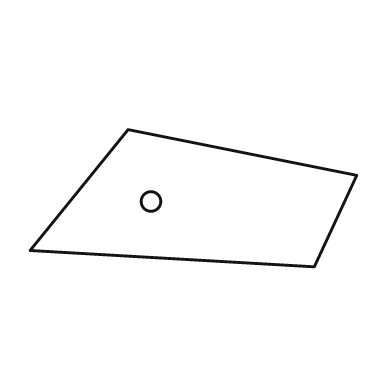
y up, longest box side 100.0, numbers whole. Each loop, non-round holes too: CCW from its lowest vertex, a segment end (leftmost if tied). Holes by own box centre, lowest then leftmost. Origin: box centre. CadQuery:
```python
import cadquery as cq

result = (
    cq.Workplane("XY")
    .moveTo(37.0, -21.0)
    .lineTo(50.0, 7.0)
    .lineTo(-20.0, 21.0)
    .lineTo(-50.0, -16.0)
    .close()
    .moveTo(-13.0, -1.0)
    .circle(3.0)
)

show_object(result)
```